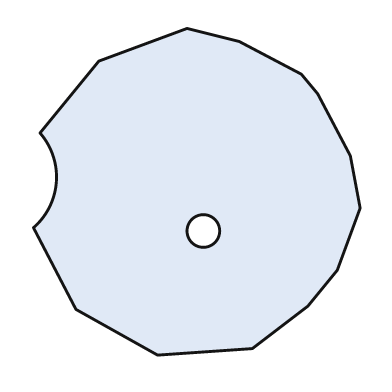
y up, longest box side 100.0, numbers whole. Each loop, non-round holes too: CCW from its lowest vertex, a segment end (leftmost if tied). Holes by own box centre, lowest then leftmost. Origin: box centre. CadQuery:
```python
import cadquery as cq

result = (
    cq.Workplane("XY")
    .moveTo(-12.0, -50.0)
    .lineTo(17.0, -48.0)
    .lineTo(34.0, -35.0)
    .lineTo(43.0, -24.0)
    .lineTo(50.0, -5.0)
    .lineTo(47.0, 11.0)
    .lineTo(37.0, 30.0)
    .lineTo(32.0, 36.0)
    .lineTo(13.0, 46.0)
    .lineTo(-3.0, 50.0)
    .lineTo(-30.0, 40.0)
    .lineTo(-48.0, 18.0)
    .threePointArc((-43.0, 3.0), (-50.0, -11.0))
    .lineTo(-37.0, -36.0)
    .close()
    .moveTo(2.0, -12.0)
    .circle(5.0)
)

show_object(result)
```